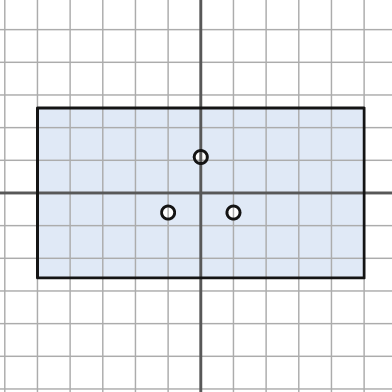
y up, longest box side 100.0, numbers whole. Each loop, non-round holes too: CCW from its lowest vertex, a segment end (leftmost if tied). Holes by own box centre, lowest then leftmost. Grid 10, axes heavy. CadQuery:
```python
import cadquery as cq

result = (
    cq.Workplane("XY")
    .moveTo(-50.0, -26.0)
    .lineTo(50.0, -26.0)
    .lineTo(50.0, 26.0)
    .lineTo(-50.0, 26.0)
    .close()
    .moveTo(-10.0, -6.0)
    .circle(2.0)
    .moveTo(10.0, -6.0)
    .circle(2.0)
    .moveTo(0.0, 11.0)
    .circle(2.0)
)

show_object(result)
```